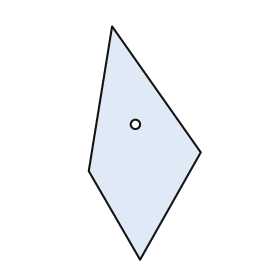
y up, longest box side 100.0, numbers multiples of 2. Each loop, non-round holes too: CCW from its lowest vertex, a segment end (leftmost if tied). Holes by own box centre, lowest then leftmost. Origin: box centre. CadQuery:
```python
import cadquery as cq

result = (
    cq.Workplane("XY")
    .moveTo(-2.0, -50.0)
    .lineTo(24.0, -4.0)
    .lineTo(-14.0, 50.0)
    .lineTo(-24.0, -12.0)
    .close()
    .moveTo(-4.0, 8.0)
    .circle(2.0)
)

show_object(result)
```